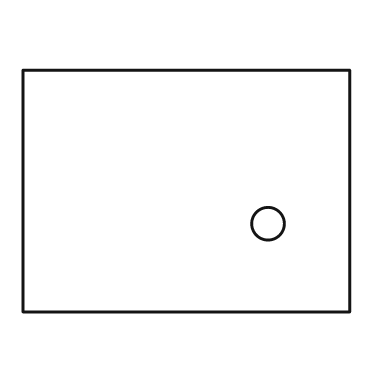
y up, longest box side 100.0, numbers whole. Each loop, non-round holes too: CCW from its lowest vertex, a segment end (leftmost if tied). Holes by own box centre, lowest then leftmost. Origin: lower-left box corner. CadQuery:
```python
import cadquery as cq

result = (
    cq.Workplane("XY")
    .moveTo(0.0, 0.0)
    .lineTo(100.0, 0.0)
    .lineTo(100.0, 74.0)
    .lineTo(0.0, 74.0)
    .close()
    .moveTo(75.0, 27.0)
    .circle(5.0)
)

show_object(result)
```